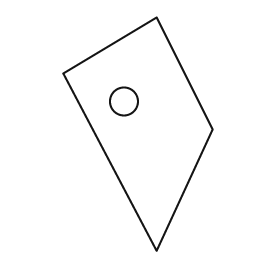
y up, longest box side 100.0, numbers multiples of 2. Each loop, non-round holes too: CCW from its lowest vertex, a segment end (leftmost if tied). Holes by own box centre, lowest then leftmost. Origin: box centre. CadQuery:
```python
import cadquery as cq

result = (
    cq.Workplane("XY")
    .moveTo(8.0, -50.0)
    .lineTo(32.0, 2.0)
    .lineTo(8.0, 50.0)
    .lineTo(-32.0, 26.0)
    .close()
    .moveTo(-6.0, 14.0)
    .circle(6.0)
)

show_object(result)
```